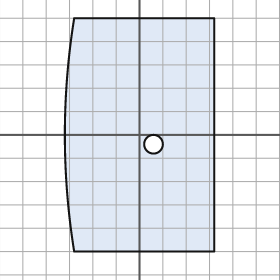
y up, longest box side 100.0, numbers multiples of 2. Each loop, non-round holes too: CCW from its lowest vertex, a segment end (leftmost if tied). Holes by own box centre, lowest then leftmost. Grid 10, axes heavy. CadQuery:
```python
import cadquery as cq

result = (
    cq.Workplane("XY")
    .moveTo(-28.0, -50.0)
    .lineTo(32.0, -50.0)
    .lineTo(32.0, 50.0)
    .lineTo(-28.0, 50.0)
    .threePointArc((-32.0, 0.0), (-28.0, -50.0))
    .close()
    .moveTo(6.0, -4.0)
    .circle(4.0)
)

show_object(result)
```